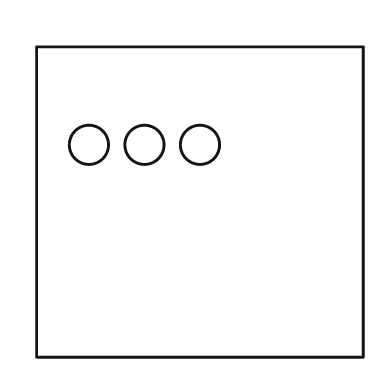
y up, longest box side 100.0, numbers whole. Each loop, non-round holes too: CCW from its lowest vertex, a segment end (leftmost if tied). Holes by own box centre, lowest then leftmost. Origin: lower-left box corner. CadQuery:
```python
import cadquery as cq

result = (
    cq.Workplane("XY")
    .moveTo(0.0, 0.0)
    .lineTo(100.0, 0.0)
    .lineTo(100.0, 95.0)
    .lineTo(0.0, 95.0)
    .close()
    .moveTo(16.0, 65.0)
    .circle(6.0)
    .moveTo(33.0, 65.0)
    .circle(6.0)
    .moveTo(50.0, 65.0)
    .circle(6.0)
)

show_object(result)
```